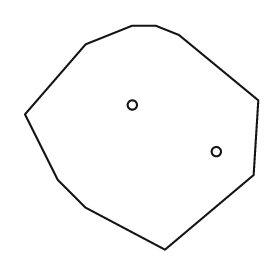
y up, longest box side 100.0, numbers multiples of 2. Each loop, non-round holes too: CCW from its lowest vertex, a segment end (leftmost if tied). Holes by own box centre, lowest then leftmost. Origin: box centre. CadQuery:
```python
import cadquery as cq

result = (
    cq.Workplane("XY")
    .moveTo(10.0, -48.0)
    .lineTo(48.0, -16.0)
    .lineTo(50.0, 16.0)
    .lineTo(16.0, 44.0)
    .lineTo(6.0, 48.0)
    .lineTo(-4.0, 48.0)
    .lineTo(-24.0, 40.0)
    .lineTo(-50.0, 10.0)
    .lineTo(-36.0, -18.0)
    .lineTo(-24.0, -30.0)
    .close()
    .moveTo(32.0, -6.0)
    .circle(2.0)
    .moveTo(-4.0, 14.0)
    .circle(2.0)
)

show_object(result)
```